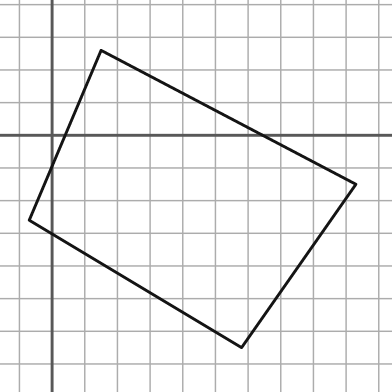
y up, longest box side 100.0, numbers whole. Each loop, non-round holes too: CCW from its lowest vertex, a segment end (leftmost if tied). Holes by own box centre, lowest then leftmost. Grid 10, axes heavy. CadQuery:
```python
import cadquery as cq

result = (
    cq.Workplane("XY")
    .moveTo(58.0, -65.0)
    .lineTo(93.0, -15.0)
    .lineTo(15.0, 26.0)
    .lineTo(-7.0, -26.0)
    .close()
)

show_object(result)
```